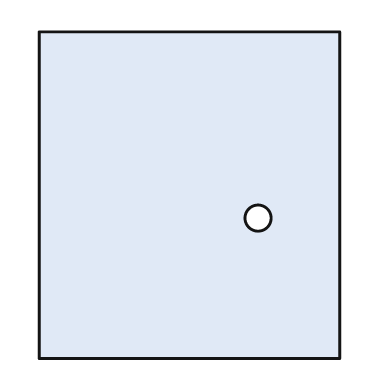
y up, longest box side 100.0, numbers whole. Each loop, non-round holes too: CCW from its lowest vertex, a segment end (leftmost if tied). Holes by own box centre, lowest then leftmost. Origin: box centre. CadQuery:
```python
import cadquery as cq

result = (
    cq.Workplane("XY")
    .moveTo(-46.0, -50.0)
    .lineTo(46.0, -50.0)
    .lineTo(46.0, 50.0)
    .lineTo(-46.0, 50.0)
    .close()
    .moveTo(21.0, -7.0)
    .circle(4.0)
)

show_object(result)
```